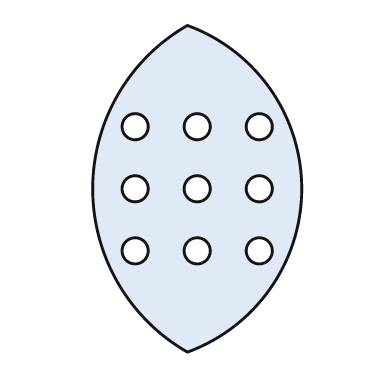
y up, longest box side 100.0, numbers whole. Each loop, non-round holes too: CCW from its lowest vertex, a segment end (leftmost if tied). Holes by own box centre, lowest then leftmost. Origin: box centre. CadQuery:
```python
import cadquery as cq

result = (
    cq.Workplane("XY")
    .moveTo(-3.0, -50.0)
    .threePointArc((32.0, 0.0), (-3.0, 50.0))
    .threePointArc((-32.0, 0.0), (-3.0, -50.0))
    .close()
    .moveTo(-19.0, -19.0)
    .circle(4.0)
    .moveTo(0.0, -19.0)
    .circle(4.0)
    .moveTo(19.0, -19.0)
    .circle(4.0)
    .moveTo(-19.0, 0.0)
    .circle(4.0)
    .moveTo(0.0, 0.0)
    .circle(4.0)
    .moveTo(19.0, 0.0)
    .circle(4.0)
    .moveTo(-19.0, 19.0)
    .circle(4.0)
    .moveTo(0.0, 19.0)
    .circle(4.0)
    .moveTo(19.0, 19.0)
    .circle(4.0)
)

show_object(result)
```